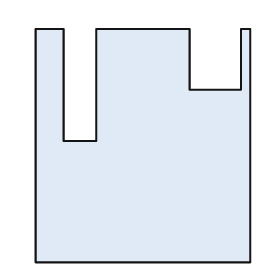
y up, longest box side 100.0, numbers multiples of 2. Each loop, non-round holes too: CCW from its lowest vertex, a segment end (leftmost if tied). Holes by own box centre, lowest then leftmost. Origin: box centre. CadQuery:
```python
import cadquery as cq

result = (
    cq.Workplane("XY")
    .moveTo(-46.0, -50.0)
    .lineTo(46.0, -50.0)
    .lineTo(46.0, 50.0)
    .lineTo(42.0, 50.0)
    .lineTo(42.0, 24.0)
    .lineTo(20.0, 24.0)
    .lineTo(20.0, 50.0)
    .lineTo(-20.0, 50.0)
    .lineTo(-20.0, 2.0)
    .lineTo(-34.0, 2.0)
    .lineTo(-34.0, 50.0)
    .lineTo(-46.0, 50.0)
    .close()
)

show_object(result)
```